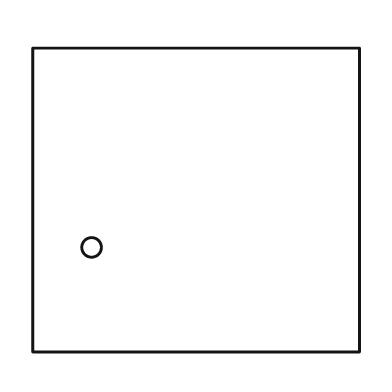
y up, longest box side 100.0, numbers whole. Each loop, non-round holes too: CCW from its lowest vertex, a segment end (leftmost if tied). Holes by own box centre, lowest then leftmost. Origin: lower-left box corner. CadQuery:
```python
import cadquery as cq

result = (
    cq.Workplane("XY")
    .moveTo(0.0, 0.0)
    .lineTo(100.0, 0.0)
    .lineTo(100.0, 93.0)
    .lineTo(0.0, 93.0)
    .close()
    .moveTo(18.0, 32.0)
    .circle(3.0)
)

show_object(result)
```